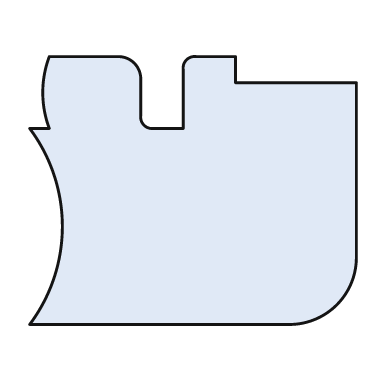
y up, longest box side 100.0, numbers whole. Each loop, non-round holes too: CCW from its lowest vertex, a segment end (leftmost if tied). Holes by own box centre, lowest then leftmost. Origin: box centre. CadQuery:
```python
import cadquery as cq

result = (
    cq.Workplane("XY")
    .moveTo(-50.0, -41.0)
    .lineTo(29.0, -41.0)
    .threePointArc((44.0, -35.0), (50.0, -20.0))
    .lineTo(50.0, 33.0)
    .lineTo(13.0, 33.0)
    .lineTo(13.0, 41.0)
    .lineTo(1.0, 41.0)
    .threePointArc((-2.0, 40.0), (-3.0, 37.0))
    .lineTo(-3.0, 19.0)
    .lineTo(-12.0, 19.0)
    .threePointArc((-15.0, 20.0), (-16.0, 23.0))
    .lineTo(-16.0, 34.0)
    .threePointArc((-18.0, 39.0), (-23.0, 41.0))
    .lineTo(-44.0, 41.0)
    .threePointArc((-46.0, 30.0), (-44.0, 19.0))
    .lineTo(-50.0, 19.0)
    .threePointArc((-40.0, -11.0), (-50.0, -41.0))
    .close()
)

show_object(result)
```